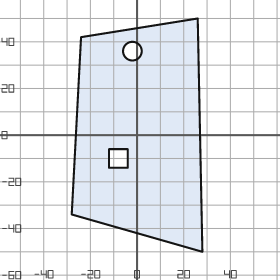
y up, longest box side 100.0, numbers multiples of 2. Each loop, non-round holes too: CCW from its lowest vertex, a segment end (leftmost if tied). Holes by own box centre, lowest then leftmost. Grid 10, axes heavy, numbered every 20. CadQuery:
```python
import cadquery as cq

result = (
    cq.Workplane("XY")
    .moveTo(28.0, -50.0)
    .lineTo(26.0, 50.0)
    .lineTo(-24.0, 42.0)
    .lineTo(-28.0, -34.0)
    .close()
    .moveTo(-12.0, -14.0)
    .lineTo(-4.0, -14.0)
    .lineTo(-4.0, -6.0)
    .lineTo(-12.0, -6.0)
    .close()
    .moveTo(-2.0, 36.0)
    .circle(4.0)
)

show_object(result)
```